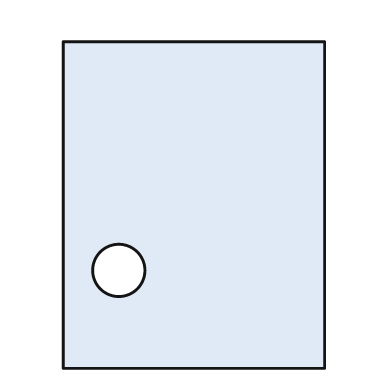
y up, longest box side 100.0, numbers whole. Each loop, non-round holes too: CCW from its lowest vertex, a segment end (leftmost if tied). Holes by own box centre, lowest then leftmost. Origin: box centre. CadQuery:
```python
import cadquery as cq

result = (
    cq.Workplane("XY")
    .moveTo(-40.0, -50.0)
    .lineTo(40.0, -50.0)
    .lineTo(40.0, 50.0)
    .lineTo(-40.0, 50.0)
    .close()
    .moveTo(-23.0, -20.0)
    .circle(8.0)
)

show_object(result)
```